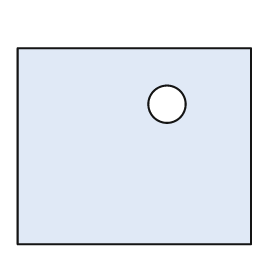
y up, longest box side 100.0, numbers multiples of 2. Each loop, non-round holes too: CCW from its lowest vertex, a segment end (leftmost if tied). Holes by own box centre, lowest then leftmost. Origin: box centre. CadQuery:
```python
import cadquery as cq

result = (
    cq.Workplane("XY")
    .moveTo(-50.0, -42.0)
    .lineTo(50.0, -42.0)
    .lineTo(50.0, 42.0)
    .lineTo(-50.0, 42.0)
    .close()
    .moveTo(14.0, 18.0)
    .circle(8.0)
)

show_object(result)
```